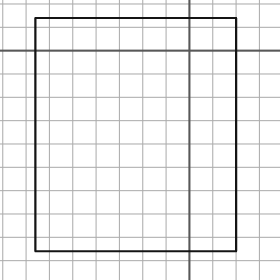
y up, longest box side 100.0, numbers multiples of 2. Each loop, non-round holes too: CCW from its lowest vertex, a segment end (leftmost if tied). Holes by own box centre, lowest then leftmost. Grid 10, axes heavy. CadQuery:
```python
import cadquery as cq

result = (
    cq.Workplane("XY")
    .moveTo(-66.0, -86.0)
    .lineTo(20.0, -86.0)
    .lineTo(20.0, 14.0)
    .lineTo(-66.0, 14.0)
    .close()
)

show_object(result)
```